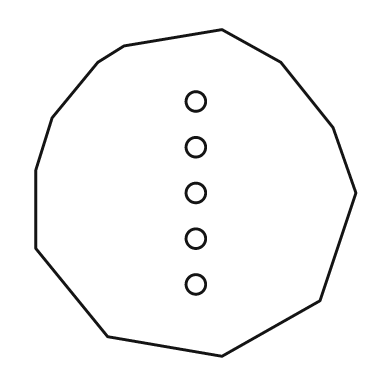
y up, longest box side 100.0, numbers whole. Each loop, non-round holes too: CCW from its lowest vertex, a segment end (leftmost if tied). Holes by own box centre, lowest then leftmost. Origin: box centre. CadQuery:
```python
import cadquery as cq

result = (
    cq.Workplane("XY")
    .moveTo(8.0, -50.0)
    .lineTo(38.0, -33.0)
    .lineTo(49.0, 0.0)
    .lineTo(42.0, 20.0)
    .lineTo(26.0, 40.0)
    .lineTo(8.0, 50.0)
    .lineTo(-22.0, 45.0)
    .lineTo(-30.0, 40.0)
    .lineTo(-44.0, 23.0)
    .lineTo(-49.0, 7.0)
    .lineTo(-49.0, -17.0)
    .lineTo(-27.0, -44.0)
    .close()
    .moveTo(0.0, -28.0)
    .circle(3.0)
    .moveTo(0.0, -14.0)
    .circle(3.0)
    .moveTo(0.0, 0.0)
    .circle(3.0)
    .moveTo(0.0, 14.0)
    .circle(3.0)
    .moveTo(0.0, 28.0)
    .circle(3.0)
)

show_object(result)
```